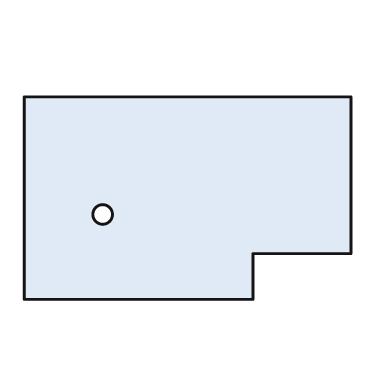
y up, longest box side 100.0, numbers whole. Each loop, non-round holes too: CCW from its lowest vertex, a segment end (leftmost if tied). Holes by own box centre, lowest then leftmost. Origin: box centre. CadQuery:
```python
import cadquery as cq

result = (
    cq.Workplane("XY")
    .moveTo(-50.0, -31.0)
    .lineTo(20.0, -31.0)
    .lineTo(20.0, -17.0)
    .lineTo(50.0, -17.0)
    .lineTo(50.0, 31.0)
    .lineTo(-50.0, 31.0)
    .close()
    .moveTo(-26.0, -5.0)
    .circle(3.0)
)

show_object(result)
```